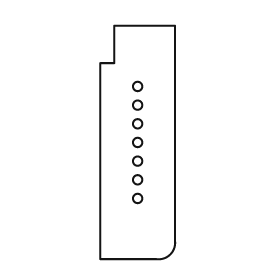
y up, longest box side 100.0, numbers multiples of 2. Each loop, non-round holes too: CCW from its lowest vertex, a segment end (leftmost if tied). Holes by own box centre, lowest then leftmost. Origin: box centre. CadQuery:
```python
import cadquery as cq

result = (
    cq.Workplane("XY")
    .moveTo(-16.0, -50.0)
    .lineTo(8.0, -50.0)
    .threePointArc((14.0, -48.0), (16.0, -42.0))
    .lineTo(16.0, 50.0)
    .lineTo(-10.0, 50.0)
    .lineTo(-10.0, 34.0)
    .lineTo(-16.0, 34.0)
    .close()
    .moveTo(0.0, -24.0)
    .circle(2.0)
    .moveTo(0.0, -16.0)
    .circle(2.0)
    .moveTo(0.0, -8.0)
    .circle(2.0)
    .moveTo(0.0, 0.0)
    .circle(2.0)
    .moveTo(0.0, 8.0)
    .circle(2.0)
    .moveTo(0.0, 16.0)
    .circle(2.0)
    .moveTo(0.0, 24.0)
    .circle(2.0)
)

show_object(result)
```